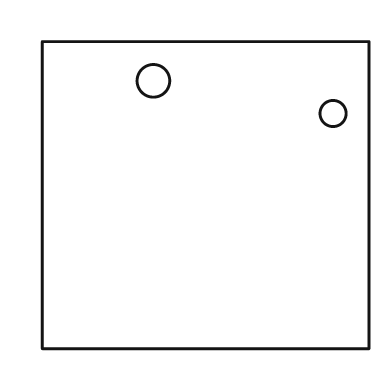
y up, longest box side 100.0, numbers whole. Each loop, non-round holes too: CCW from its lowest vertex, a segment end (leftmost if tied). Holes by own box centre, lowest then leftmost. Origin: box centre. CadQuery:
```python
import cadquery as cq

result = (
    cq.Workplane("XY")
    .moveTo(-50.0, -47.0)
    .lineTo(50.0, -47.0)
    .lineTo(50.0, 47.0)
    .lineTo(-50.0, 47.0)
    .close()
    .moveTo(39.0, 25.0)
    .circle(4.0)
    .moveTo(-16.0, 35.0)
    .circle(5.0)
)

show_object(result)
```